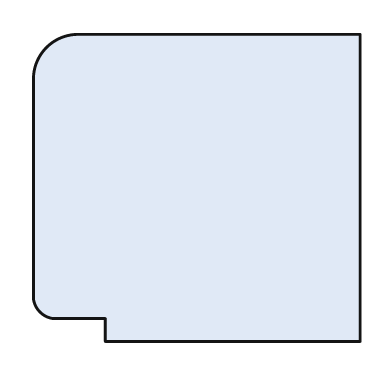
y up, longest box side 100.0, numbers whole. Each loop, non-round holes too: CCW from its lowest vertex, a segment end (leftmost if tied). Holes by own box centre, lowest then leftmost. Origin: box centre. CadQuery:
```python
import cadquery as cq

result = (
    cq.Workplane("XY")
    .moveTo(-28.0, -47.0)
    .lineTo(50.0, -47.0)
    .lineTo(50.0, 47.0)
    .lineTo(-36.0, 47.0)
    .threePointArc((-46.0, 43.0), (-50.0, 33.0))
    .lineTo(-50.0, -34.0)
    .threePointArc((-48.0, -38.0), (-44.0, -40.0))
    .lineTo(-28.0, -40.0)
    .close()
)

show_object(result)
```